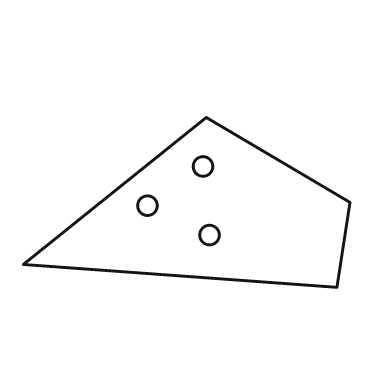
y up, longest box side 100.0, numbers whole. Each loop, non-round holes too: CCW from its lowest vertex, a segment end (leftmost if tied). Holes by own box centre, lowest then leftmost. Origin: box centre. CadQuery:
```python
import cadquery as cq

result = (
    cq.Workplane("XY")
    .moveTo(46.0, -26.0)
    .lineTo(50.0, 0.0)
    .lineTo(6.0, 26.0)
    .lineTo(-50.0, -19.0)
    .close()
    .moveTo(7.0, -10.0)
    .circle(3.0)
    .moveTo(-12.0, -1.0)
    .circle(3.0)
    .moveTo(5.0, 11.0)
    .circle(3.0)
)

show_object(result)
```